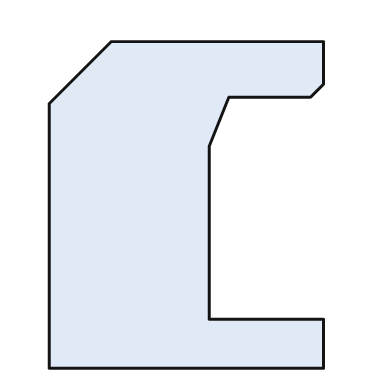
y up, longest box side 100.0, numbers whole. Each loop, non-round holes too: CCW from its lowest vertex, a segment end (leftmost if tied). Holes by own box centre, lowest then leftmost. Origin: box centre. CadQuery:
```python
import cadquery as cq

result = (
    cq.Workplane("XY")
    .moveTo(-42.0, -50.0)
    .lineTo(42.0, -50.0)
    .lineTo(42.0, -35.0)
    .lineTo(7.0, -35.0)
    .lineTo(7.0, 18.0)
    .lineTo(13.0, 33.0)
    .lineTo(38.0, 33.0)
    .lineTo(42.0, 37.0)
    .lineTo(42.0, 50.0)
    .lineTo(-23.0, 50.0)
    .lineTo(-42.0, 31.0)
    .close()
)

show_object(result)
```